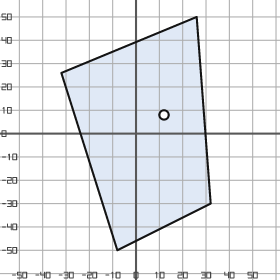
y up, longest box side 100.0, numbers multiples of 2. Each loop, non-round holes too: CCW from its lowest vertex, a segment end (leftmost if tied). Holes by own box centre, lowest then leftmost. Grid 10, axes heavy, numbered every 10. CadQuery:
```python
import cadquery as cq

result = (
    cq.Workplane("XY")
    .moveTo(-8.0, -50.0)
    .lineTo(32.0, -30.0)
    .lineTo(26.0, 50.0)
    .lineTo(-32.0, 26.0)
    .close()
    .moveTo(12.0, 8.0)
    .circle(2.0)
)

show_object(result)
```